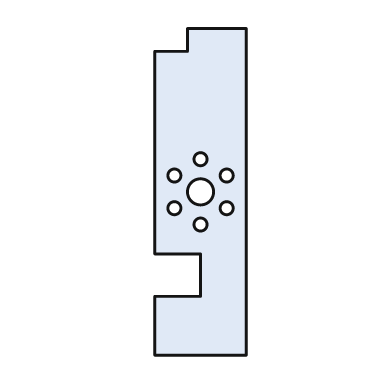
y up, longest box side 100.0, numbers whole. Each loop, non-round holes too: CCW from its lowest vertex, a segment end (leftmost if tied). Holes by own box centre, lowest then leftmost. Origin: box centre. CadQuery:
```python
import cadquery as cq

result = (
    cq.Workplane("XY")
    .moveTo(-14.0, -50.0)
    .lineTo(14.0, -50.0)
    .lineTo(14.0, 50.0)
    .lineTo(-4.0, 50.0)
    .lineTo(-4.0, 43.0)
    .lineTo(-14.0, 43.0)
    .lineTo(-14.0, -19.0)
    .lineTo(0.0, -19.0)
    .lineTo(0.0, -32.0)
    .lineTo(-14.0, -32.0)
    .close()
    .moveTo(0.0, -10.0)
    .circle(2.0)
    .moveTo(-8.0, -5.0)
    .circle(2.0)
    .moveTo(8.0, -5.0)
    .circle(2.0)
    .moveTo(0.0, 0.0)
    .circle(4.0)
    .moveTo(-8.0, 5.0)
    .circle(2.0)
    .moveTo(8.0, 5.0)
    .circle(2.0)
    .moveTo(0.0, 10.0)
    .circle(2.0)
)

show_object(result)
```